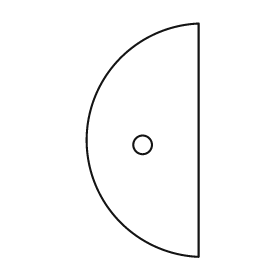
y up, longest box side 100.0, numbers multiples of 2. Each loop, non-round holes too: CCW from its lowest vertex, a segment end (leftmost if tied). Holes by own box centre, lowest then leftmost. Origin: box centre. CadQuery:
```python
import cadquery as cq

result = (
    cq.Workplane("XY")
    .moveTo(24.0, -50.0)
    .lineTo(24.0, 50.0)
    .threePointArc((-24.0, 0.0), (24.0, -50.0))
    .close()
    .moveTo(0.0, -2.0)
    .circle(4.0)
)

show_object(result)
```